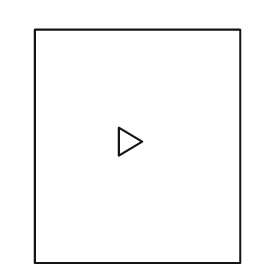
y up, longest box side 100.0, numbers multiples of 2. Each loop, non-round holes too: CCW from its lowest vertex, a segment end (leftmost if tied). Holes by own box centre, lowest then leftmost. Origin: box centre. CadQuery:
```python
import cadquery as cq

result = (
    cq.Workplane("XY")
    .moveTo(-44.0, -50.0)
    .lineTo(44.0, -50.0)
    .lineTo(44.0, 50.0)
    .lineTo(-44.0, 50.0)
    .close()
    .moveTo(-8.0, -4.0)
    .lineTo(2.0, 2.0)
    .lineTo(-8.0, 8.0)
    .close()
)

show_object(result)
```